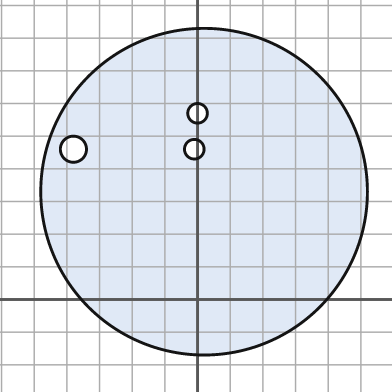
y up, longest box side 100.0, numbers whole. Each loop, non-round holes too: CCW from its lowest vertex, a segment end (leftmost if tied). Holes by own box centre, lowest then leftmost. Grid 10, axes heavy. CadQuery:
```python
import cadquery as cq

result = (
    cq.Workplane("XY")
    .moveTo(2.0, 33.0)
    .circle(50.0)
    .moveTo(-38.0, 46.0)
    .circle(4.0)
    .moveTo(-1.0, 46.0)
    .circle(3.0)
    .moveTo(0.0, 57.0)
    .circle(3.0)
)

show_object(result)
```